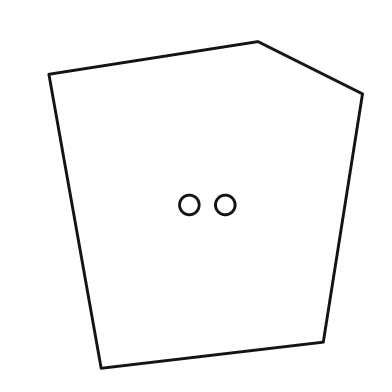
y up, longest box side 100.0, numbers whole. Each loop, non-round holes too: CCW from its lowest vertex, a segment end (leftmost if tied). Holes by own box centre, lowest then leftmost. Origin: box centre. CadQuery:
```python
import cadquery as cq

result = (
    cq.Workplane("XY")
    .moveTo(-32.0, -50.0)
    .lineTo(36.0, -42.0)
    .lineTo(48.0, 34.0)
    .lineTo(16.0, 50.0)
    .lineTo(-48.0, 40.0)
    .close()
    .moveTo(-5.0, 0.0)
    .circle(3.0)
    .moveTo(6.0, 0.0)
    .circle(3.0)
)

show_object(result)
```